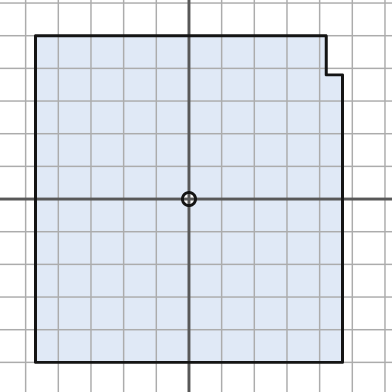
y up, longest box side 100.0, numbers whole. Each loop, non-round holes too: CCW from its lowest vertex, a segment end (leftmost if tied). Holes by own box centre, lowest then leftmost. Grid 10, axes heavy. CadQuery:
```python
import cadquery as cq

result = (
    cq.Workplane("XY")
    .moveTo(-47.0, -50.0)
    .lineTo(47.0, -50.0)
    .lineTo(47.0, 38.0)
    .lineTo(42.0, 38.0)
    .lineTo(42.0, 50.0)
    .lineTo(-47.0, 50.0)
    .close()
    .moveTo(0.0, 0.0)
    .circle(2.0)
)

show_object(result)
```